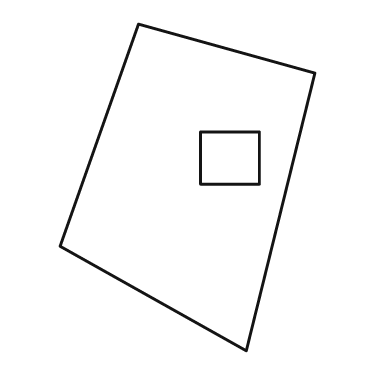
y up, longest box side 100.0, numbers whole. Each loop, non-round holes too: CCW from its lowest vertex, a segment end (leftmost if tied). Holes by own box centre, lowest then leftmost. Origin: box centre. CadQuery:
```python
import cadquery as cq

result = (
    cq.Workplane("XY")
    .moveTo(18.0, -50.0)
    .lineTo(39.0, 35.0)
    .lineTo(-15.0, 50.0)
    .lineTo(-39.0, -18.0)
    .close()
    .moveTo(4.0, 1.0)
    .lineTo(22.0, 1.0)
    .lineTo(22.0, 17.0)
    .lineTo(4.0, 17.0)
    .close()
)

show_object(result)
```